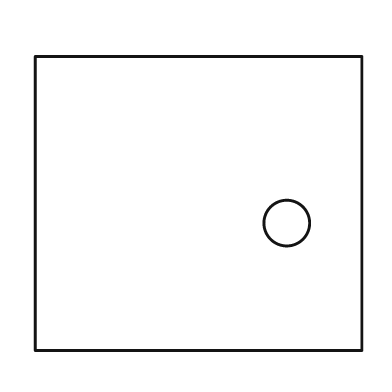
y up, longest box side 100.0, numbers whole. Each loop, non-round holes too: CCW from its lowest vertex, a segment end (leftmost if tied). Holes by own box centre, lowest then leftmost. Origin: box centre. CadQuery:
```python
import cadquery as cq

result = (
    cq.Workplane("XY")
    .moveTo(-50.0, -45.0)
    .lineTo(50.0, -45.0)
    .lineTo(50.0, 45.0)
    .lineTo(-50.0, 45.0)
    .close()
    .moveTo(27.0, -6.0)
    .circle(7.0)
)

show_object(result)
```